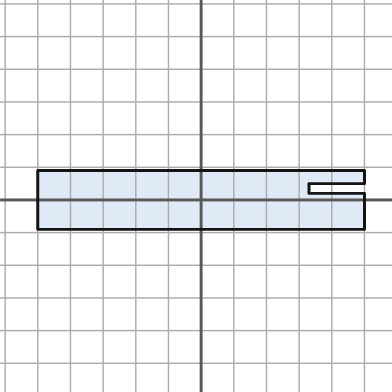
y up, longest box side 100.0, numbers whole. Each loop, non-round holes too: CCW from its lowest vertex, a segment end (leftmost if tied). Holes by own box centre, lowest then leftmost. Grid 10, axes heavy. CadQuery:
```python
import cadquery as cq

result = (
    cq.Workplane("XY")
    .moveTo(-50.0, -9.0)
    .lineTo(50.0, -9.0)
    .lineTo(50.0, 2.0)
    .lineTo(33.0, 2.0)
    .lineTo(33.0, 5.0)
    .lineTo(50.0, 5.0)
    .lineTo(50.0, 9.0)
    .lineTo(-50.0, 9.0)
    .close()
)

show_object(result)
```